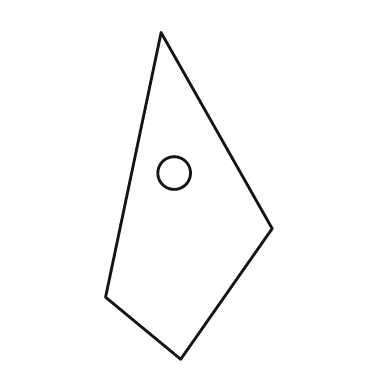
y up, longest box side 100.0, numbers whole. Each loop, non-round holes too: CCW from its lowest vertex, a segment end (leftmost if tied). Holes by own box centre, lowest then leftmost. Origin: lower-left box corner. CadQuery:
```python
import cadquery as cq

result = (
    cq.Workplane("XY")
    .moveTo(23.0, 0.0)
    .lineTo(51.0, 40.0)
    .lineTo(17.0, 100.0)
    .lineTo(0.0, 19.0)
    .close()
    .moveTo(21.0, 57.0)
    .circle(5.0)
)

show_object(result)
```